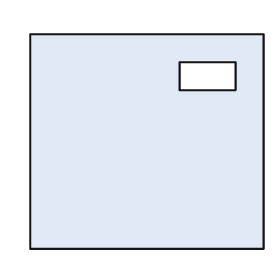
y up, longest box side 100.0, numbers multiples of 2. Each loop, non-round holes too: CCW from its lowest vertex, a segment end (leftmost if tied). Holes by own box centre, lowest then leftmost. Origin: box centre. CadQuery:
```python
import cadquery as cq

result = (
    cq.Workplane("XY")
    .moveTo(-50.0, -46.0)
    .lineTo(50.0, -46.0)
    .lineTo(50.0, 46.0)
    .lineTo(-50.0, 46.0)
    .close()
    .moveTo(14.0, 22.0)
    .lineTo(38.0, 22.0)
    .lineTo(38.0, 34.0)
    .lineTo(14.0, 34.0)
    .close()
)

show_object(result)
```